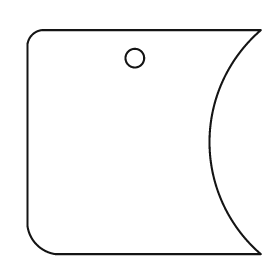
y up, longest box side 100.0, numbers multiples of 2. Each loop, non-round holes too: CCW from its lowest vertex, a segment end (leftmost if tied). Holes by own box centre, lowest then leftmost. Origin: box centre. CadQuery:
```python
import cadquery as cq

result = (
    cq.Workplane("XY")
    .moveTo(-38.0, -48.0)
    .lineTo(50.0, -48.0)
    .threePointArc((28.0, 0.0), (50.0, 48.0))
    .lineTo(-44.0, 48.0)
    .threePointArc((-48.0, 46.0), (-50.0, 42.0))
    .lineTo(-50.0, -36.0)
    .threePointArc((-46.0, -44.0), (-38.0, -48.0))
    .close()
    .moveTo(-4.0, 36.0)
    .circle(4.0)
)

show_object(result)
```